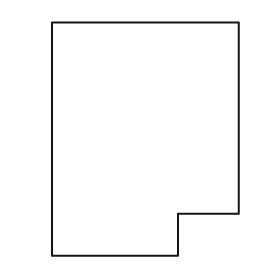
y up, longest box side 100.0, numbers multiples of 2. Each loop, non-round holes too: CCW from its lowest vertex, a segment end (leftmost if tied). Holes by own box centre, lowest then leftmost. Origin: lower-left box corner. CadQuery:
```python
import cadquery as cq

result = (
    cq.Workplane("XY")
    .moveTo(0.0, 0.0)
    .lineTo(54.0, 0.0)
    .lineTo(54.0, 18.0)
    .lineTo(80.0, 18.0)
    .lineTo(80.0, 100.0)
    .lineTo(0.0, 100.0)
    .close()
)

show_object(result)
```